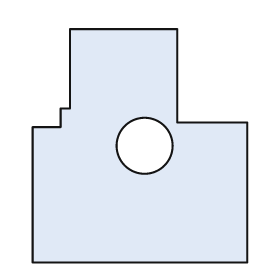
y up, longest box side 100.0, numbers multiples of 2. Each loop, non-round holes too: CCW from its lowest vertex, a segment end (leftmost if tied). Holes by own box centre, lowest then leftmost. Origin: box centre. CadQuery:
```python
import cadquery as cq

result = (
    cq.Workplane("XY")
    .moveTo(-46.0, -50.0)
    .lineTo(46.0, -50.0)
    .lineTo(46.0, 10.0)
    .lineTo(16.0, 10.0)
    .lineTo(16.0, 50.0)
    .lineTo(-30.0, 50.0)
    .lineTo(-30.0, 16.0)
    .lineTo(-34.0, 16.0)
    .lineTo(-34.0, 8.0)
    .lineTo(-46.0, 8.0)
    .close()
    .moveTo(2.0, 0.0)
    .circle(12.0)
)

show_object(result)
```